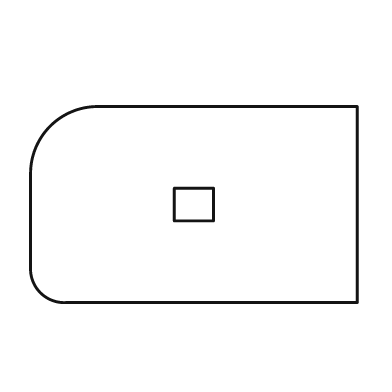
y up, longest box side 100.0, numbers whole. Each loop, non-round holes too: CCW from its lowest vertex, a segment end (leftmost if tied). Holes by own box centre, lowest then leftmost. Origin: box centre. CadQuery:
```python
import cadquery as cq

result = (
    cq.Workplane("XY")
    .moveTo(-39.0, -30.0)
    .lineTo(50.0, -30.0)
    .lineTo(50.0, 30.0)
    .lineTo(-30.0, 30.0)
    .threePointArc((-44.0, 24.0), (-50.0, 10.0))
    .lineTo(-50.0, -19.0)
    .threePointArc((-47.0, -27.0), (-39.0, -30.0))
    .close()
    .moveTo(-6.0, -5.0)
    .lineTo(6.0, -5.0)
    .lineTo(6.0, 5.0)
    .lineTo(-6.0, 5.0)
    .close()
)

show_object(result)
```